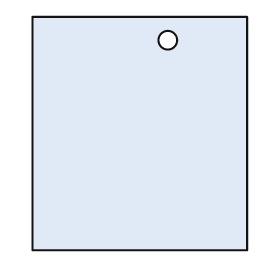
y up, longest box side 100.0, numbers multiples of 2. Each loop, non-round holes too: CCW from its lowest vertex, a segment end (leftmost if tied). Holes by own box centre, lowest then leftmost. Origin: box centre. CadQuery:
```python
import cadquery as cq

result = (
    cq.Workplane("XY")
    .moveTo(-46.0, -50.0)
    .lineTo(46.0, -50.0)
    .lineTo(46.0, 50.0)
    .lineTo(-46.0, 50.0)
    .close()
    .moveTo(12.0, 40.0)
    .circle(4.0)
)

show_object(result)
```